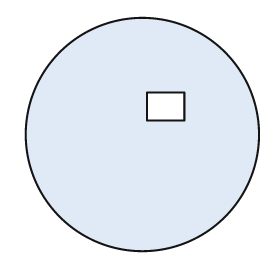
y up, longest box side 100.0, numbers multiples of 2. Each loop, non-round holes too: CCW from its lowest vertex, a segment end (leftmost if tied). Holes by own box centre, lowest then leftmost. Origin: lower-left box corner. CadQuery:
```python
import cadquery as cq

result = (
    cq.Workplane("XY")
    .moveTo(50.0, 50.0)
    .circle(50.0)
    .moveTo(52.0, 56.0)
    .lineTo(68.0, 56.0)
    .lineTo(68.0, 68.0)
    .lineTo(52.0, 68.0)
    .close()
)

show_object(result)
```